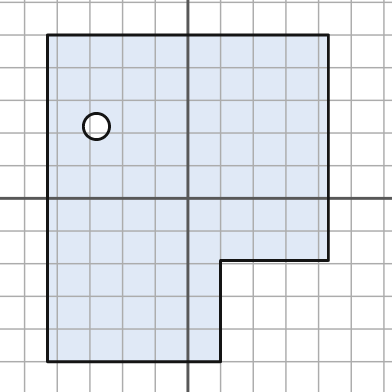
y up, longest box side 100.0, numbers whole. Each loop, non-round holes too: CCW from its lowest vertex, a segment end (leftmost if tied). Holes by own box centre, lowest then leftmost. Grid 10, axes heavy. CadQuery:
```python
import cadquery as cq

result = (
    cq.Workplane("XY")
    .moveTo(-43.0, -50.0)
    .lineTo(10.0, -50.0)
    .lineTo(10.0, -19.0)
    .lineTo(43.0, -19.0)
    .lineTo(43.0, 50.0)
    .lineTo(-43.0, 50.0)
    .close()
    .moveTo(-28.0, 22.0)
    .circle(4.0)
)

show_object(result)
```